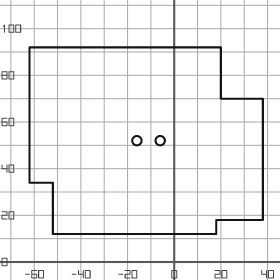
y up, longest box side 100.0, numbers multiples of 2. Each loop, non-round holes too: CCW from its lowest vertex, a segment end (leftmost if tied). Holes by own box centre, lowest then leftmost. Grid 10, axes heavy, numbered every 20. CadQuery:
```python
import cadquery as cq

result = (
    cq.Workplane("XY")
    .moveTo(-52.0, 12.0)
    .lineTo(18.0, 12.0)
    .lineTo(18.0, 18.0)
    .lineTo(38.0, 18.0)
    .lineTo(38.0, 70.0)
    .lineTo(20.0, 70.0)
    .lineTo(20.0, 92.0)
    .lineTo(-62.0, 92.0)
    .lineTo(-62.0, 34.0)
    .lineTo(-52.0, 34.0)
    .close()
    .moveTo(-16.0, 52.0)
    .circle(2.0)
    .moveTo(-6.0, 52.0)
    .circle(2.0)
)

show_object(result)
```